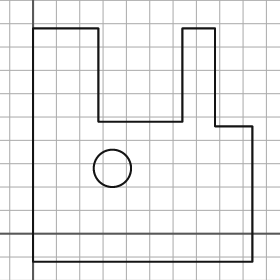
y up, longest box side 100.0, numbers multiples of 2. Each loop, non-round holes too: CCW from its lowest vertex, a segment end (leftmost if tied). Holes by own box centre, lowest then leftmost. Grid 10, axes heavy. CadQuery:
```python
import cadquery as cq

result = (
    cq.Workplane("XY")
    .moveTo(0.0, -12.0)
    .lineTo(94.0, -12.0)
    .lineTo(94.0, 46.0)
    .lineTo(78.0, 46.0)
    .lineTo(78.0, 88.0)
    .lineTo(64.0, 88.0)
    .lineTo(64.0, 48.0)
    .lineTo(28.0, 48.0)
    .lineTo(28.0, 88.0)
    .lineTo(0.0, 88.0)
    .close()
    .moveTo(34.0, 28.0)
    .circle(8.0)
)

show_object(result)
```